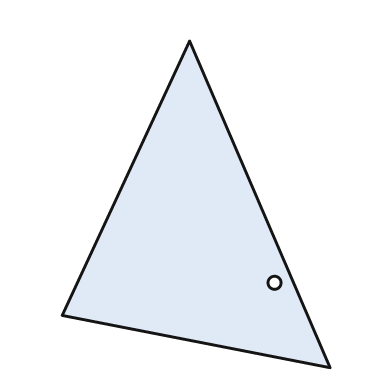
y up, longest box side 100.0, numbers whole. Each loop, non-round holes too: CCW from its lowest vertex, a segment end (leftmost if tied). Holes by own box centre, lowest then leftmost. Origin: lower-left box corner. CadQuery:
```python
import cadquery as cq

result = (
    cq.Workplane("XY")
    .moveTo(82.0, 0.0)
    .lineTo(39.0, 100.0)
    .lineTo(0.0, 16.0)
    .close()
    .moveTo(65.0, 26.0)
    .circle(2.0)
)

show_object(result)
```